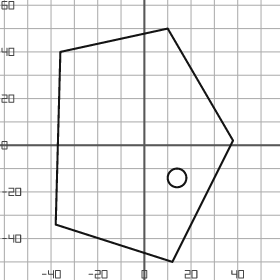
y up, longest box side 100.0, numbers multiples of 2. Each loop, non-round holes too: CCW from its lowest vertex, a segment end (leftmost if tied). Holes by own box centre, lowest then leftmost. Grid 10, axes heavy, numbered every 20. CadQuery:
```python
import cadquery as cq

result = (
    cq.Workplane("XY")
    .moveTo(12.0, -50.0)
    .lineTo(38.0, 2.0)
    .lineTo(10.0, 50.0)
    .lineTo(-36.0, 40.0)
    .lineTo(-38.0, -34.0)
    .close()
    .moveTo(14.0, -14.0)
    .circle(4.0)
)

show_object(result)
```